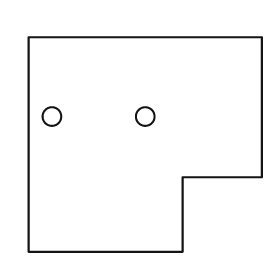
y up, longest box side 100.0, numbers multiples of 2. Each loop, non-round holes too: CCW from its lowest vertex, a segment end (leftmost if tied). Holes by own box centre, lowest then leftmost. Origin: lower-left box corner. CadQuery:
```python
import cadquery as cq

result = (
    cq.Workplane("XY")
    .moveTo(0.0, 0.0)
    .lineTo(66.0, 0.0)
    .lineTo(66.0, 32.0)
    .lineTo(100.0, 32.0)
    .lineTo(100.0, 92.0)
    .lineTo(0.0, 92.0)
    .close()
    .moveTo(10.0, 58.0)
    .circle(4.0)
    .moveTo(50.0, 58.0)
    .circle(4.0)
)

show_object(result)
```